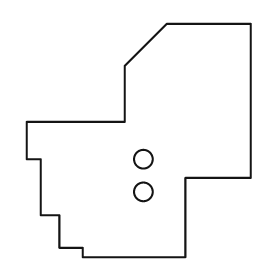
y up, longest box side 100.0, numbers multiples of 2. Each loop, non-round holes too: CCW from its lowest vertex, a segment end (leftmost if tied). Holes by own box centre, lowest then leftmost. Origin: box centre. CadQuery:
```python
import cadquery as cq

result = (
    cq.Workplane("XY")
    .moveTo(-24.0, -50.0)
    .lineTo(20.0, -50.0)
    .lineTo(20.0, -16.0)
    .lineTo(48.0, -16.0)
    .lineTo(48.0, 50.0)
    .lineTo(12.0, 50.0)
    .lineTo(-6.0, 32.0)
    .lineTo(-6.0, 8.0)
    .lineTo(-48.0, 8.0)
    .lineTo(-48.0, -8.0)
    .lineTo(-42.0, -8.0)
    .lineTo(-42.0, -32.0)
    .lineTo(-34.0, -32.0)
    .lineTo(-34.0, -46.0)
    .lineTo(-24.0, -46.0)
    .close()
    .moveTo(2.0, -22.0)
    .circle(4.0)
    .moveTo(2.0, -8.0)
    .circle(4.0)
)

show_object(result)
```